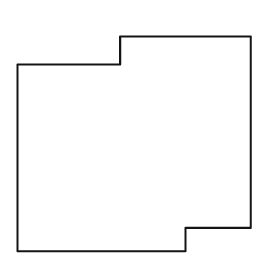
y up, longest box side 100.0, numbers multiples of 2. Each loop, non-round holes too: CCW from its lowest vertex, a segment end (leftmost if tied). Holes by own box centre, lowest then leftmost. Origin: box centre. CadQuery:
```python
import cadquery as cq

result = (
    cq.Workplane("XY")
    .moveTo(-50.0, -46.0)
    .lineTo(22.0, -46.0)
    .lineTo(22.0, -36.0)
    .lineTo(50.0, -36.0)
    .lineTo(50.0, 46.0)
    .lineTo(-6.0, 46.0)
    .lineTo(-6.0, 34.0)
    .lineTo(-50.0, 34.0)
    .close()
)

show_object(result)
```